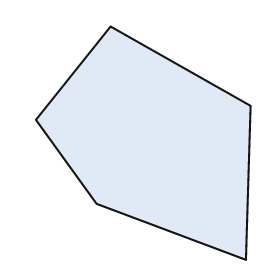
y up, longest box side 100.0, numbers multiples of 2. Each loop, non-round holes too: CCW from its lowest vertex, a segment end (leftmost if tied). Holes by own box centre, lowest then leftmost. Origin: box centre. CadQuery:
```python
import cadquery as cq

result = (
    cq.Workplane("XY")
    .moveTo(44.0, -50.0)
    .lineTo(46.0, 16.0)
    .lineTo(-14.0, 50.0)
    .lineTo(-46.0, 10.0)
    .lineTo(-20.0, -26.0)
    .close()
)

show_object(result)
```